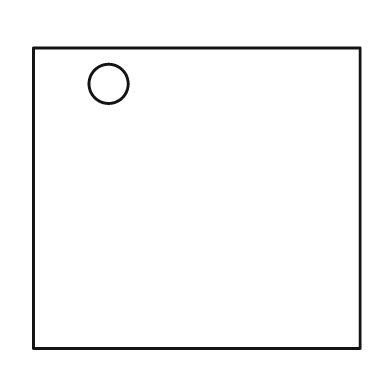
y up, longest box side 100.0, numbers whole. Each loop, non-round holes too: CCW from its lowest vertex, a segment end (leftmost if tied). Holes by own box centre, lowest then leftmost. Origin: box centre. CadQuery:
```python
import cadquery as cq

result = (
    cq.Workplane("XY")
    .moveTo(-50.0, -46.0)
    .lineTo(50.0, -46.0)
    .lineTo(50.0, 46.0)
    .lineTo(-50.0, 46.0)
    .close()
    .moveTo(-27.0, 35.0)
    .circle(6.0)
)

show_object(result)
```